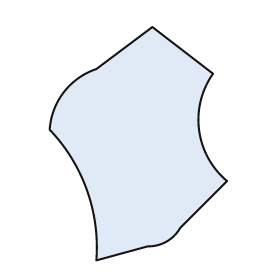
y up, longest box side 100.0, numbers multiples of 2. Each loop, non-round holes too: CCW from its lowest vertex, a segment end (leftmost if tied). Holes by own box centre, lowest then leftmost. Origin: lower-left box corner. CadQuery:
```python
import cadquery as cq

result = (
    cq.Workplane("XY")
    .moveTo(20.0, 0.0)
    .lineTo(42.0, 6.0)
    .threePointArc((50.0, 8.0), (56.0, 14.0))
    .lineTo(76.0, 34.0)
    .threePointArc((64.0, 56.0), (70.0, 80.0))
    .lineTo(44.0, 100.0)
    .lineTo(20.0, 82.0)
    .threePointArc((6.0, 72.0), (0.0, 56.0))
    .threePointArc((16.0, 30.0), (20.0, 0.0))
    .close()
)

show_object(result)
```